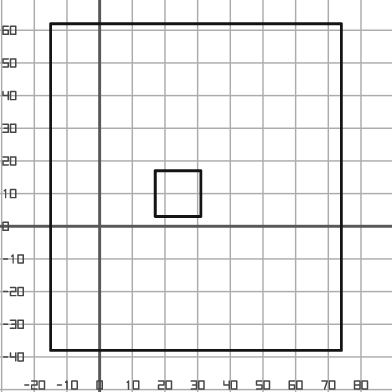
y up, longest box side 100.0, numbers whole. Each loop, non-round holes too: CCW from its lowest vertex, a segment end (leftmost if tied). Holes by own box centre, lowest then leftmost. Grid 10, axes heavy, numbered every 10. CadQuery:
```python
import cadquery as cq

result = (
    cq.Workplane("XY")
    .moveTo(-15.0, -38.0)
    .lineTo(74.0, -38.0)
    .lineTo(74.0, 62.0)
    .lineTo(-15.0, 62.0)
    .close()
    .moveTo(17.0, 3.0)
    .lineTo(31.0, 3.0)
    .lineTo(31.0, 17.0)
    .lineTo(17.0, 17.0)
    .close()
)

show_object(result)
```